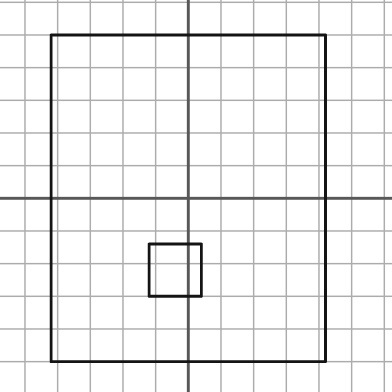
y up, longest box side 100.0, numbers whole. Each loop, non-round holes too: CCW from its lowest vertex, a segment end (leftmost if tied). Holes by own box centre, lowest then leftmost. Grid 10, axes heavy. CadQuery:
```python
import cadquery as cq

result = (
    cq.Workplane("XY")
    .moveTo(-42.0, -50.0)
    .lineTo(42.0, -50.0)
    .lineTo(42.0, 50.0)
    .lineTo(-42.0, 50.0)
    .close()
    .moveTo(-12.0, -30.0)
    .lineTo(4.0, -30.0)
    .lineTo(4.0, -14.0)
    .lineTo(-12.0, -14.0)
    .close()
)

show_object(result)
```